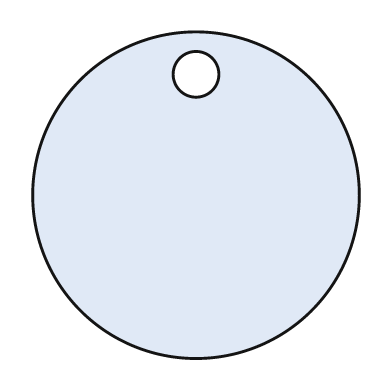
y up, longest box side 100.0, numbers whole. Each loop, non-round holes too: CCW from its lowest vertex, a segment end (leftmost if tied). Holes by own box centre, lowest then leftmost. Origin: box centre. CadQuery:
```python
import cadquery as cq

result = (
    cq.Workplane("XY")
    .moveTo(0.0, 0.0)
    .circle(50.0)
    .moveTo(0.0, 37.0)
    .circle(7.0)
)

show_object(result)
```